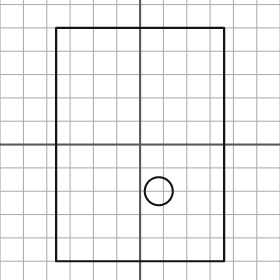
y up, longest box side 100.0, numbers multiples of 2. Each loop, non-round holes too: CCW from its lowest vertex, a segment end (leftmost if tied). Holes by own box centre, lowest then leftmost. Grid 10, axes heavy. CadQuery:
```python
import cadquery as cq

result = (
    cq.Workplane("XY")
    .moveTo(-36.0, -50.0)
    .lineTo(36.0, -50.0)
    .lineTo(36.0, 50.0)
    .lineTo(-36.0, 50.0)
    .close()
    .moveTo(8.0, -20.0)
    .circle(6.0)
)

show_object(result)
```